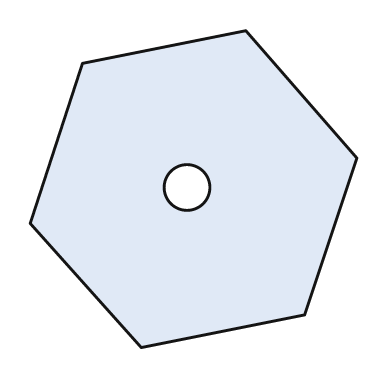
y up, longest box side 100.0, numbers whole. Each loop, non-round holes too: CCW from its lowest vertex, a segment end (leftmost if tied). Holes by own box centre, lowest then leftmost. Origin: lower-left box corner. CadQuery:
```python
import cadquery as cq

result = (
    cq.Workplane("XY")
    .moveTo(34.0, 0.0)
    .lineTo(84.0, 10.0)
    .lineTo(100.0, 58.0)
    .lineTo(66.0, 97.0)
    .lineTo(16.0, 87.0)
    .lineTo(0.0, 38.0)
    .close()
    .moveTo(48.0, 49.0)
    .circle(7.0)
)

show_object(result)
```